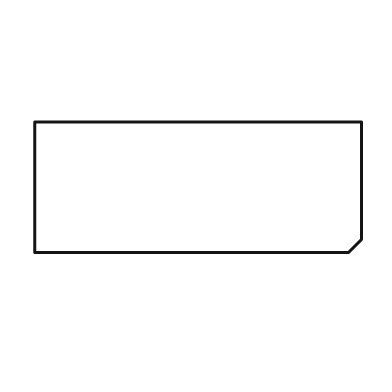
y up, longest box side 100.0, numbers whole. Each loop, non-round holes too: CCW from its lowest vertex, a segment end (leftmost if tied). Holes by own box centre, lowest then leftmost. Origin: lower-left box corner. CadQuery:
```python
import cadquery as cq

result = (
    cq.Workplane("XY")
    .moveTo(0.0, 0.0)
    .lineTo(96.0, 0.0)
    .lineTo(100.0, 4.0)
    .lineTo(100.0, 40.0)
    .lineTo(0.0, 40.0)
    .close()
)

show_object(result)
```